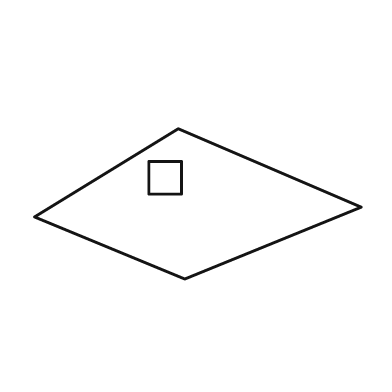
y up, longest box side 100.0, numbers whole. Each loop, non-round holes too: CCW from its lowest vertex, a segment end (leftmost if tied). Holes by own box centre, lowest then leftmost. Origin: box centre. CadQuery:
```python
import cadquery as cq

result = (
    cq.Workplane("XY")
    .moveTo(-4.0, -23.0)
    .lineTo(50.0, -1.0)
    .lineTo(-6.0, 23.0)
    .lineTo(-50.0, -4.0)
    .close()
    .moveTo(-15.0, 3.0)
    .lineTo(-5.0, 3.0)
    .lineTo(-5.0, 13.0)
    .lineTo(-15.0, 13.0)
    .close()
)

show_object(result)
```